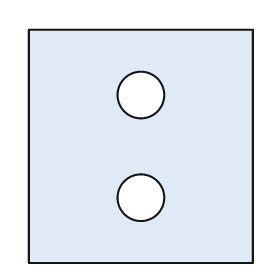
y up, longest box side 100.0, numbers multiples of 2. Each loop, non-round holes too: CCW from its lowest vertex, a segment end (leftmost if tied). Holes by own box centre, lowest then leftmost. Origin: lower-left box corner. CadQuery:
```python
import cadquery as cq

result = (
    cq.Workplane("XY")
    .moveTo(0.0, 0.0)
    .lineTo(96.0, 0.0)
    .lineTo(96.0, 100.0)
    .lineTo(0.0, 100.0)
    .close()
    .moveTo(48.0, 28.0)
    .circle(10.0)
    .moveTo(48.0, 72.0)
    .circle(10.0)
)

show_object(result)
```